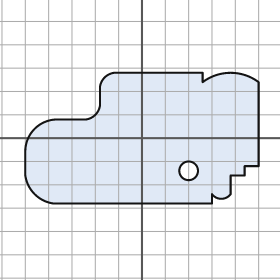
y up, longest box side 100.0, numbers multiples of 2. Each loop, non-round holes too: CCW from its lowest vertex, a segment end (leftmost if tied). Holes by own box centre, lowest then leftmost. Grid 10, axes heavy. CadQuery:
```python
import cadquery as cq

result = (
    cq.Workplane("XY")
    .moveTo(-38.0, -28.0)
    .lineTo(30.0, -28.0)
    .lineTo(30.0, -24.0)
    .threePointArc((34.0, -26.0), (38.0, -24.0))
    .lineTo(38.0, -16.0)
    .lineTo(44.0, -16.0)
    .lineTo(44.0, -12.0)
    .lineTo(50.0, -12.0)
    .lineTo(50.0, 24.0)
    .threePointArc((38.0, 28.0), (26.0, 24.0))
    .lineTo(26.0, 28.0)
    .lineTo(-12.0, 28.0)
    .threePointArc((-16.0, 26.0), (-18.0, 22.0))
    .lineTo(-18.0, 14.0)
    .threePointArc((-20.0, 10.0), (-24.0, 8.0))
    .lineTo(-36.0, 8.0)
    .threePointArc((-46.0, 4.0), (-50.0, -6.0))
    .lineTo(-50.0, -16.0)
    .threePointArc((-46.0, -24.0), (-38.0, -28.0))
    .close()
    .moveTo(20.0, -14.0)
    .circle(4.0)
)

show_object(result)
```